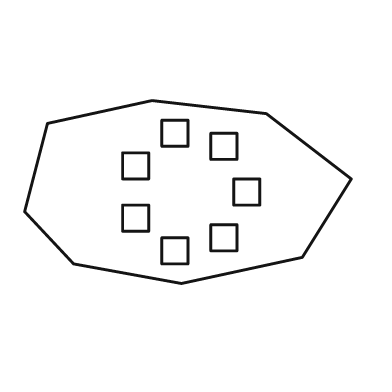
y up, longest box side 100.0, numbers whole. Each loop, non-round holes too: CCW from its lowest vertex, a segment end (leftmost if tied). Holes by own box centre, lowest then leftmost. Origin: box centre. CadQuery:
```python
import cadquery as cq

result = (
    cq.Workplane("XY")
    .moveTo(-2.0, -28.0)
    .lineTo(35.0, -20.0)
    .lineTo(50.0, 4.0)
    .lineTo(24.0, 24.0)
    .lineTo(-11.0, 28.0)
    .lineTo(-43.0, 21.0)
    .lineTo(-50.0, -6.0)
    .lineTo(-35.0, -22.0)
    .close()
    .moveTo(-8.0, -22.0)
    .lineTo(0.0, -22.0)
    .lineTo(0.0, -14.0)
    .lineTo(-8.0, -14.0)
    .close()
    .moveTo(7.0, -18.0)
    .lineTo(15.0, -18.0)
    .lineTo(15.0, -10.0)
    .lineTo(7.0, -10.0)
    .close()
    .moveTo(-20.0, -12.0)
    .lineTo(-12.0, -12.0)
    .lineTo(-12.0, -4.0)
    .lineTo(-20.0, -4.0)
    .close()
    .moveTo(14.0, -4.0)
    .lineTo(22.0, -4.0)
    .lineTo(22.0, 4.0)
    .lineTo(14.0, 4.0)
    .close()
    .moveTo(-20.0, 4.0)
    .lineTo(-12.0, 4.0)
    .lineTo(-12.0, 12.0)
    .lineTo(-20.0, 12.0)
    .close()
    .moveTo(7.0, 10.0)
    .lineTo(15.0, 10.0)
    .lineTo(15.0, 18.0)
    .lineTo(7.0, 18.0)
    .close()
    .moveTo(-8.0, 14.0)
    .lineTo(0.0, 14.0)
    .lineTo(0.0, 22.0)
    .lineTo(-8.0, 22.0)
    .close()
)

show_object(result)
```